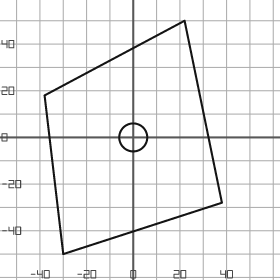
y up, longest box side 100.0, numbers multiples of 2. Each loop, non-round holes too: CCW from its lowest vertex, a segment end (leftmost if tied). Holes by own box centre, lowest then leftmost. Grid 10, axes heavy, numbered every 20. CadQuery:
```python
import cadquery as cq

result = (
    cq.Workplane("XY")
    .moveTo(-30.0, -50.0)
    .lineTo(38.0, -28.0)
    .lineTo(22.0, 50.0)
    .lineTo(-38.0, 18.0)
    .close()
    .moveTo(0.0, 0.0)
    .circle(6.0)
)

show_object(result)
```